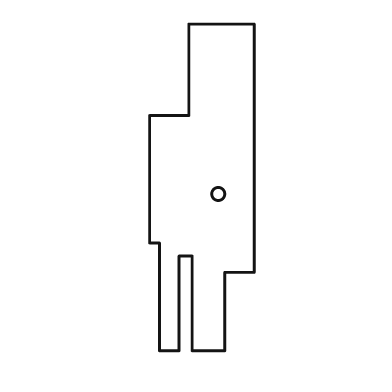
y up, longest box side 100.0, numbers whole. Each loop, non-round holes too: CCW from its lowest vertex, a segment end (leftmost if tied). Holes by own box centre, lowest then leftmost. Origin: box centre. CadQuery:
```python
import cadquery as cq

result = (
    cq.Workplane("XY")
    .moveTo(-13.0, -50.0)
    .lineTo(-7.0, -50.0)
    .lineTo(-7.0, -21.0)
    .lineTo(-3.0, -21.0)
    .lineTo(-3.0, -50.0)
    .lineTo(7.0, -50.0)
    .lineTo(7.0, -26.0)
    .lineTo(16.0, -26.0)
    .lineTo(16.0, 50.0)
    .lineTo(-4.0, 50.0)
    .lineTo(-4.0, 22.0)
    .lineTo(-16.0, 22.0)
    .lineTo(-16.0, -17.0)
    .lineTo(-13.0, -17.0)
    .close()
    .moveTo(5.0, -2.0)
    .circle(2.0)
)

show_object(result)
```